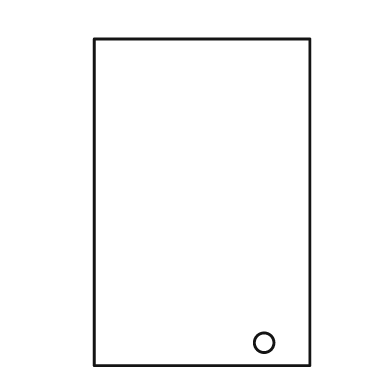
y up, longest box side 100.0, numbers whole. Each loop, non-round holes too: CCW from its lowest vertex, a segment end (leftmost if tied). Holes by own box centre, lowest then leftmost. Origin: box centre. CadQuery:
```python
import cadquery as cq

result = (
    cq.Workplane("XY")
    .moveTo(-33.0, -50.0)
    .lineTo(33.0, -50.0)
    .lineTo(33.0, 50.0)
    .lineTo(-33.0, 50.0)
    .close()
    .moveTo(19.0, -43.0)
    .circle(3.0)
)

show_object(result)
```